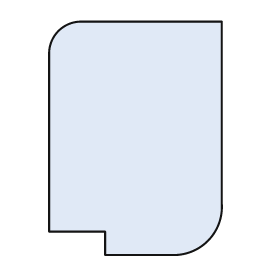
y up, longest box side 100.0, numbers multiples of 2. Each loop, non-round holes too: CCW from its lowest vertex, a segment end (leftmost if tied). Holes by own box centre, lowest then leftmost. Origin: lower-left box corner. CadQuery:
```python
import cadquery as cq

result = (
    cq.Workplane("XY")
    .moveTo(24.0, 0.0)
    .lineTo(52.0, 0.0)
    .threePointArc((68.0, 6.0), (74.0, 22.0))
    .lineTo(74.0, 100.0)
    .lineTo(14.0, 100.0)
    .threePointArc((4.0, 96.0), (0.0, 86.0))
    .lineTo(0.0, 10.0)
    .lineTo(24.0, 10.0)
    .close()
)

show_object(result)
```